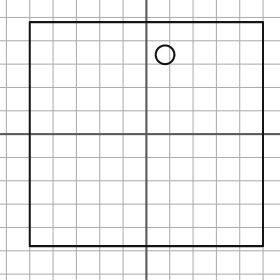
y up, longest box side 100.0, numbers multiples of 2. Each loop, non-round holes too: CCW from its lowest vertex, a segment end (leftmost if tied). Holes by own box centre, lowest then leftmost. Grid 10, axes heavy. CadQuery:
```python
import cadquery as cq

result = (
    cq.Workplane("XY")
    .moveTo(-50.0, -48.0)
    .lineTo(50.0, -48.0)
    .lineTo(50.0, 48.0)
    .lineTo(-50.0, 48.0)
    .close()
    .moveTo(8.0, 34.0)
    .circle(4.0)
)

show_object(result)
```